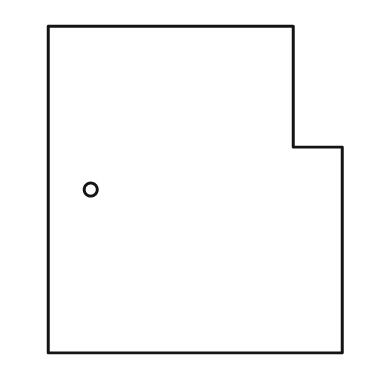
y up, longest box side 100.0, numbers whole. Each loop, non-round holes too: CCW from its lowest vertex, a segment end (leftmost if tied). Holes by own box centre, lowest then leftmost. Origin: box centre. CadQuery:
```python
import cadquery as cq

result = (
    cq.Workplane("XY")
    .moveTo(-45.0, -50.0)
    .lineTo(45.0, -50.0)
    .lineTo(45.0, 13.0)
    .lineTo(30.0, 13.0)
    .lineTo(30.0, 50.0)
    .lineTo(-45.0, 50.0)
    .close()
    .moveTo(-32.0, 0.0)
    .circle(2.0)
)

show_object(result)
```